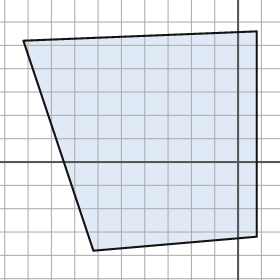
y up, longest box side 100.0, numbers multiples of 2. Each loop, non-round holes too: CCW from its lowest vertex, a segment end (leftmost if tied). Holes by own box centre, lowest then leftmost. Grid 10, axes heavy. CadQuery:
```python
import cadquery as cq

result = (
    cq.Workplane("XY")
    .moveTo(-62.0, -38.0)
    .lineTo(8.0, -32.0)
    .lineTo(8.0, 56.0)
    .lineTo(-92.0, 52.0)
    .close()
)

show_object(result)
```